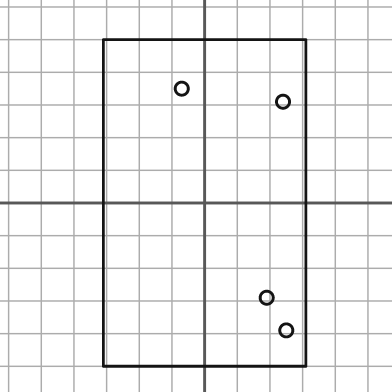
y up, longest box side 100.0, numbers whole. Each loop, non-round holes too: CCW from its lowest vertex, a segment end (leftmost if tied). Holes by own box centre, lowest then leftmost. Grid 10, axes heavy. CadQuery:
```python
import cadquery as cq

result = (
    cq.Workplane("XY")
    .moveTo(-31.0, -50.0)
    .lineTo(31.0, -50.0)
    .lineTo(31.0, 50.0)
    .lineTo(-31.0, 50.0)
    .close()
    .moveTo(25.0, -39.0)
    .circle(2.0)
    .moveTo(19.0, -29.0)
    .circle(2.0)
    .moveTo(24.0, 31.0)
    .circle(2.0)
    .moveTo(-7.0, 35.0)
    .circle(2.0)
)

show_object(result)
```